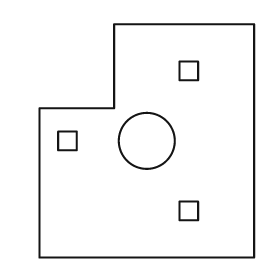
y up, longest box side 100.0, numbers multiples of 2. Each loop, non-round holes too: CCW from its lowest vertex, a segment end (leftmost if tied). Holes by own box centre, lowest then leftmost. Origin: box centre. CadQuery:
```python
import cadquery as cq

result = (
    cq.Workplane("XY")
    .moveTo(-46.0, -50.0)
    .lineTo(46.0, -50.0)
    .lineTo(46.0, 50.0)
    .lineTo(-14.0, 50.0)
    .lineTo(-14.0, 14.0)
    .lineTo(-46.0, 14.0)
    .close()
    .moveTo(14.0, -34.0)
    .lineTo(22.0, -34.0)
    .lineTo(22.0, -26.0)
    .lineTo(14.0, -26.0)
    .close()
    .moveTo(-38.0, -4.0)
    .lineTo(-30.0, -4.0)
    .lineTo(-30.0, 4.0)
    .lineTo(-38.0, 4.0)
    .close()
    .moveTo(0.0, 0.0)
    .circle(12.0)
    .moveTo(14.0, 26.0)
    .lineTo(22.0, 26.0)
    .lineTo(22.0, 34.0)
    .lineTo(14.0, 34.0)
    .close()
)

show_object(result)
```